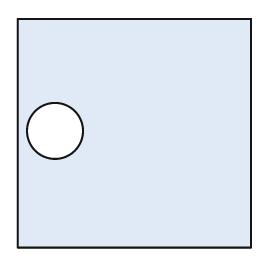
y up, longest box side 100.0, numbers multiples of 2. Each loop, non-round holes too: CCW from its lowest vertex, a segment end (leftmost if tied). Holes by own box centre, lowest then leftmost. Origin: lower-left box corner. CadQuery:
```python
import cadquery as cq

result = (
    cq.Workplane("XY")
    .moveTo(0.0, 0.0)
    .lineTo(100.0, 0.0)
    .lineTo(100.0, 98.0)
    .lineTo(0.0, 98.0)
    .close()
    .moveTo(16.0, 50.0)
    .circle(12.0)
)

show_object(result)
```